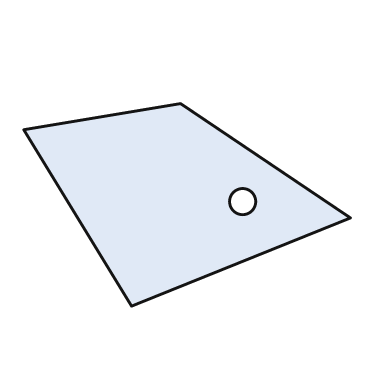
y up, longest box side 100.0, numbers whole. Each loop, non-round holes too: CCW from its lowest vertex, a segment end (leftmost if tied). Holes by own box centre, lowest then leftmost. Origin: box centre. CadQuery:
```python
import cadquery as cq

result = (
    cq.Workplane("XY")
    .moveTo(-17.0, -31.0)
    .lineTo(50.0, -4.0)
    .lineTo(-2.0, 31.0)
    .lineTo(-50.0, 23.0)
    .close()
    .moveTo(17.0, 1.0)
    .circle(4.0)
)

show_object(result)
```